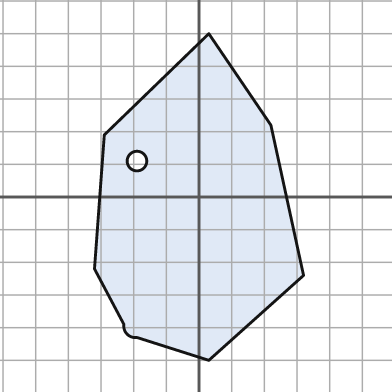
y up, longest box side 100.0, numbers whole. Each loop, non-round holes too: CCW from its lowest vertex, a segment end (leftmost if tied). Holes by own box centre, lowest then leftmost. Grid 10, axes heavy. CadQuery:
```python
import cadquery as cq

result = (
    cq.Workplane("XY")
    .moveTo(3.0, -50.0)
    .lineTo(32.0, -24.0)
    .lineTo(22.0, 22.0)
    .lineTo(3.0, 50.0)
    .lineTo(-29.0, 19.0)
    .lineTo(-32.0, -22.0)
    .lineTo(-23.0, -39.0)
    .threePointArc((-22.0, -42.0), (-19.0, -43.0))
    .close()
    .moveTo(-19.0, 11.0)
    .circle(3.0)
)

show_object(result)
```